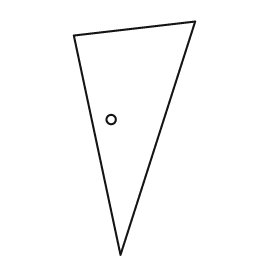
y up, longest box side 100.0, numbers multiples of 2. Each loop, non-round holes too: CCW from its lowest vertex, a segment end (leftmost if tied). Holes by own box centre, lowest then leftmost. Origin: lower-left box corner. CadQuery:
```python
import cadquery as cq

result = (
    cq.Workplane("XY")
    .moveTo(20.0, 0.0)
    .lineTo(52.0, 100.0)
    .lineTo(0.0, 94.0)
    .close()
    .moveTo(16.0, 58.0)
    .circle(2.0)
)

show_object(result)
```